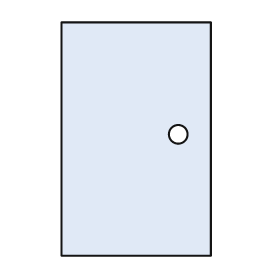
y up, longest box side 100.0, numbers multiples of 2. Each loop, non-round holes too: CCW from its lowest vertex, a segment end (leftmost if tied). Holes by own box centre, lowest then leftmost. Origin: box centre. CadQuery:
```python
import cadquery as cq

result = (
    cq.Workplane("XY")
    .moveTo(-32.0, -50.0)
    .lineTo(32.0, -50.0)
    .lineTo(32.0, 50.0)
    .lineTo(-32.0, 50.0)
    .close()
    .moveTo(18.0, 2.0)
    .circle(4.0)
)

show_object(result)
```